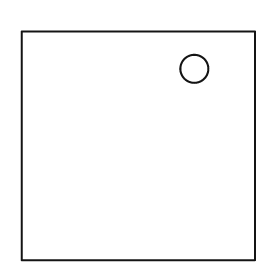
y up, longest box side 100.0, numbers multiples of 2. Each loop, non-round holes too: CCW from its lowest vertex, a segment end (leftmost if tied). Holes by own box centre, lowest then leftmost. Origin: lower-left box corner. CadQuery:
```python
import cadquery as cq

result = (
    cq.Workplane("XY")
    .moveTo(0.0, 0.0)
    .lineTo(100.0, 0.0)
    .lineTo(100.0, 98.0)
    .lineTo(0.0, 98.0)
    .close()
    .moveTo(74.0, 82.0)
    .circle(6.0)
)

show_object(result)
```